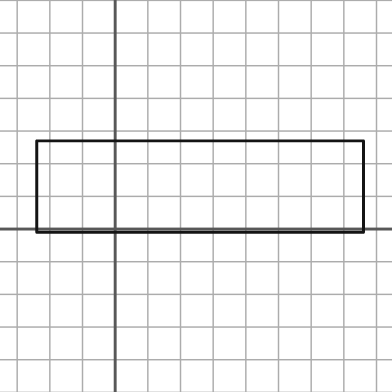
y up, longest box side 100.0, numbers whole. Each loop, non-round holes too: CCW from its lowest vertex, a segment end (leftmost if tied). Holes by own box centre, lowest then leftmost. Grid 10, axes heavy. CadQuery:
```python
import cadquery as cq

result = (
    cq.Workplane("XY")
    .moveTo(-24.0, -1.0)
    .lineTo(76.0, -1.0)
    .lineTo(76.0, 27.0)
    .lineTo(-24.0, 27.0)
    .close()
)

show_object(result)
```